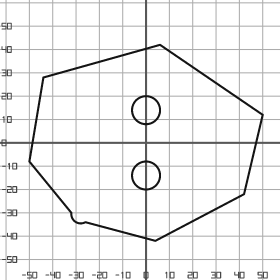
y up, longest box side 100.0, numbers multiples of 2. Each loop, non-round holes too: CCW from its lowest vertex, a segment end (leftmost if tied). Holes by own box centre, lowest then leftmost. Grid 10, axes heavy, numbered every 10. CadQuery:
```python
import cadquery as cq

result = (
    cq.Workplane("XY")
    .moveTo(4.0, -42.0)
    .lineTo(42.0, -22.0)
    .lineTo(50.0, 12.0)
    .lineTo(6.0, 42.0)
    .lineTo(-44.0, 28.0)
    .lineTo(-50.0, -8.0)
    .lineTo(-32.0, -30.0)
    .threePointArc((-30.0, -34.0), (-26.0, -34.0))
    .close()
    .moveTo(0.0, -14.0)
    .circle(6.0)
    .moveTo(0.0, 14.0)
    .circle(6.0)
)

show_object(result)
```